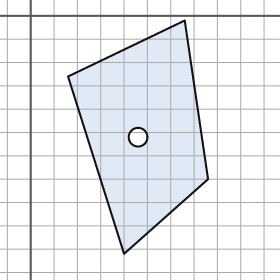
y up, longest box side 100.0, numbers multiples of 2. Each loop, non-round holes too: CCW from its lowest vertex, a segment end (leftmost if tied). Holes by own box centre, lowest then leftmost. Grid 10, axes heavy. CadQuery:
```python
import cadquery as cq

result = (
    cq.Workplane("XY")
    .moveTo(40.0, -102.0)
    .lineTo(76.0, -70.0)
    .lineTo(66.0, -2.0)
    .lineTo(16.0, -26.0)
    .close()
    .moveTo(46.0, -52.0)
    .circle(4.0)
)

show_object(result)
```